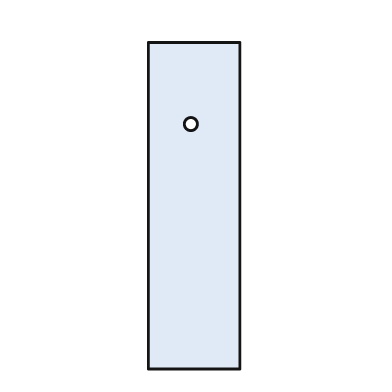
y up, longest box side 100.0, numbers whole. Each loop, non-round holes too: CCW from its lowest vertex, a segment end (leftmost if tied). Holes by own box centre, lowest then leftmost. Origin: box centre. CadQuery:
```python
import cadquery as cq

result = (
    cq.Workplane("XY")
    .moveTo(-14.0, -50.0)
    .lineTo(14.0, -50.0)
    .lineTo(14.0, 50.0)
    .lineTo(-14.0, 50.0)
    .close()
    .moveTo(-1.0, 25.0)
    .circle(2.0)
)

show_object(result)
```